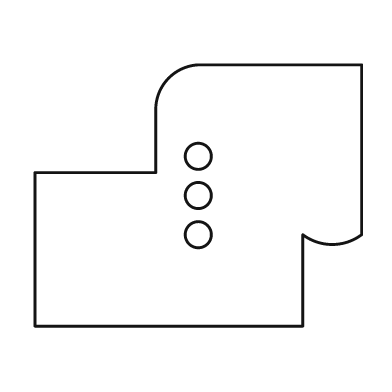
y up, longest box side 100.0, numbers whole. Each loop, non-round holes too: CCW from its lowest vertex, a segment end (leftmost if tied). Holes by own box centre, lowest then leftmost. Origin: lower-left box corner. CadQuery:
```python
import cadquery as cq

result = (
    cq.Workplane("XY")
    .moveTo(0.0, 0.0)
    .lineTo(82.0, 0.0)
    .lineTo(82.0, 28.0)
    .threePointArc((91.0, 25.0), (100.0, 28.0))
    .lineTo(100.0, 80.0)
    .lineTo(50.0, 80.0)
    .threePointArc((41.0, 76.0), (37.0, 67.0))
    .lineTo(37.0, 47.0)
    .lineTo(0.0, 47.0)
    .close()
    .moveTo(50.0, 28.0)
    .circle(4.0)
    .moveTo(50.0, 40.0)
    .circle(4.0)
    .moveTo(50.0, 52.0)
    .circle(4.0)
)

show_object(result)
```